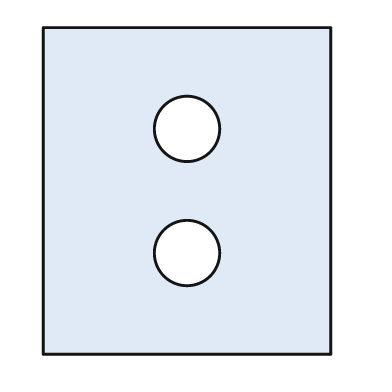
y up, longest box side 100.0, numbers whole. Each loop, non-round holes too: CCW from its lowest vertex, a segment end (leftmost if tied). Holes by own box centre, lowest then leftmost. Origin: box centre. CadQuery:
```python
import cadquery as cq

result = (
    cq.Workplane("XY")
    .moveTo(-44.0, -50.0)
    .lineTo(44.0, -50.0)
    .lineTo(44.0, 50.0)
    .lineTo(-44.0, 50.0)
    .close()
    .moveTo(0.0, -19.0)
    .circle(10.0)
    .moveTo(0.0, 19.0)
    .circle(10.0)
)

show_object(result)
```